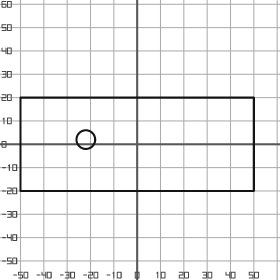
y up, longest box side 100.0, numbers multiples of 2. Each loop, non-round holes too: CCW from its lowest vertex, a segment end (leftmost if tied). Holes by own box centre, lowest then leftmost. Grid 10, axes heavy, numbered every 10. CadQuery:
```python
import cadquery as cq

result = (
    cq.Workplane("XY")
    .moveTo(-50.0, -20.0)
    .lineTo(50.0, -20.0)
    .lineTo(50.0, 20.0)
    .lineTo(-50.0, 20.0)
    .close()
    .moveTo(-22.0, 2.0)
    .circle(4.0)
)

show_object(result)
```